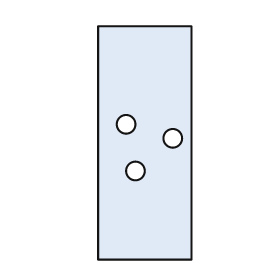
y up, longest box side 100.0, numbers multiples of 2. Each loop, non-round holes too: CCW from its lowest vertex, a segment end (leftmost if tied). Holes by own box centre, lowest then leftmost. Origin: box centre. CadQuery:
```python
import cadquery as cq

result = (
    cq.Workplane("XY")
    .moveTo(-20.0, -50.0)
    .lineTo(20.0, -50.0)
    .lineTo(20.0, 50.0)
    .lineTo(-20.0, 50.0)
    .close()
    .moveTo(-4.0, -12.0)
    .circle(4.0)
    .moveTo(12.0, 2.0)
    .circle(4.0)
    .moveTo(-8.0, 8.0)
    .circle(4.0)
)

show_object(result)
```